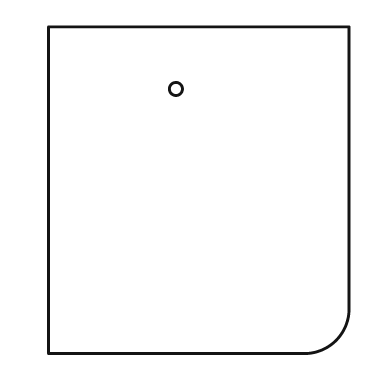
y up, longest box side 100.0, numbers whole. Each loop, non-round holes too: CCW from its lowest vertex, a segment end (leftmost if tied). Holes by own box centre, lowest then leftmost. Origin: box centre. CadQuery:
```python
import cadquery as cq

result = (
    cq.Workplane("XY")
    .moveTo(-46.0, -50.0)
    .lineTo(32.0, -50.0)
    .threePointArc((42.0, -46.0), (46.0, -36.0))
    .lineTo(46.0, 50.0)
    .lineTo(-46.0, 50.0)
    .close()
    .moveTo(-7.0, 31.0)
    .circle(2.0)
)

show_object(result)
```